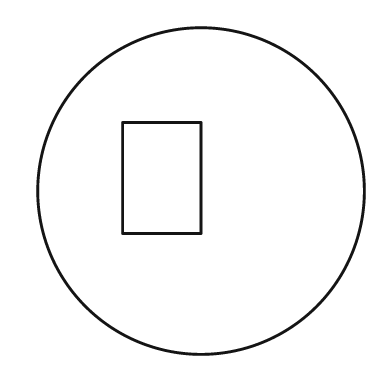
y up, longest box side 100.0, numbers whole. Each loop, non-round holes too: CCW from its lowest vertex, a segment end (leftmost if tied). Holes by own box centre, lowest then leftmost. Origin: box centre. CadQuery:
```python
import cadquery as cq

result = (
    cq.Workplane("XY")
    .moveTo(0.0, 0.0)
    .circle(50.0)
    .moveTo(-24.0, -13.0)
    .lineTo(0.0, -13.0)
    .lineTo(0.0, 21.0)
    .lineTo(-24.0, 21.0)
    .close()
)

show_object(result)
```